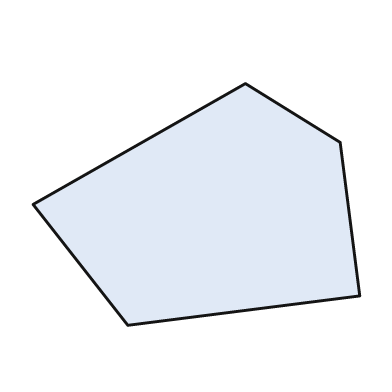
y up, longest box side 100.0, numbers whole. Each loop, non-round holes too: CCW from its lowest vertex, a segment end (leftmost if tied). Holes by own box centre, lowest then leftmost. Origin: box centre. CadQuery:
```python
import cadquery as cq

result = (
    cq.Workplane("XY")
    .moveTo(-21.0, -37.0)
    .lineTo(50.0, -28.0)
    .lineTo(44.0, 19.0)
    .lineTo(15.0, 37.0)
    .lineTo(-50.0, 0.0)
    .close()
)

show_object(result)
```